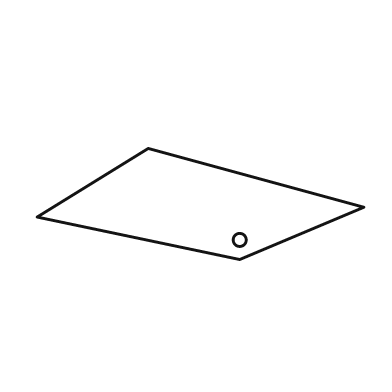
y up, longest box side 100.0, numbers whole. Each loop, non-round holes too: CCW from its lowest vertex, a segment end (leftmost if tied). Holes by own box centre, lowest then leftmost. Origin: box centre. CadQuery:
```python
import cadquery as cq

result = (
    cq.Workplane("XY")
    .moveTo(12.0, -17.0)
    .lineTo(50.0, -1.0)
    .lineTo(-16.0, 17.0)
    .lineTo(-50.0, -4.0)
    .close()
    .moveTo(12.0, -11.0)
    .circle(2.0)
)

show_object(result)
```